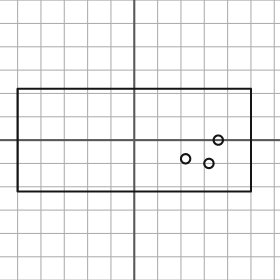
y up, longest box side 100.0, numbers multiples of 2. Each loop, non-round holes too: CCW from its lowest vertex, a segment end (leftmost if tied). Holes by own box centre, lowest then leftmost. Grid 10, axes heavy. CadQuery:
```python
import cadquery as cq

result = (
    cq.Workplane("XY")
    .moveTo(-50.0, -22.0)
    .lineTo(50.0, -22.0)
    .lineTo(50.0, 22.0)
    .lineTo(-50.0, 22.0)
    .close()
    .moveTo(32.0, -10.0)
    .circle(2.0)
    .moveTo(22.0, -8.0)
    .circle(2.0)
    .moveTo(36.0, 0.0)
    .circle(2.0)
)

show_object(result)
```